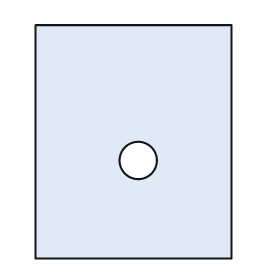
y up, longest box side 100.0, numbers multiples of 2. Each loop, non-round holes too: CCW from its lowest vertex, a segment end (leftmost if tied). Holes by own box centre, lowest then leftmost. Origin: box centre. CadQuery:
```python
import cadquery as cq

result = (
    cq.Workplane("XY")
    .moveTo(-42.0, -50.0)
    .lineTo(42.0, -50.0)
    .lineTo(42.0, 50.0)
    .lineTo(-42.0, 50.0)
    .close()
    .moveTo(2.0, -8.0)
    .circle(8.0)
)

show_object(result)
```